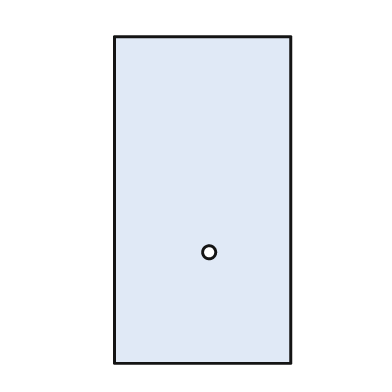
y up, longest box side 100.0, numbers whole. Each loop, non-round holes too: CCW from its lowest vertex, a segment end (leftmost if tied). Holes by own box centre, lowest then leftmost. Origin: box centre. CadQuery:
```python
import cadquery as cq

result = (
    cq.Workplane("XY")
    .moveTo(-27.0, -50.0)
    .lineTo(27.0, -50.0)
    .lineTo(27.0, 50.0)
    .lineTo(-27.0, 50.0)
    .close()
    .moveTo(2.0, -16.0)
    .circle(2.0)
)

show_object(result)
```